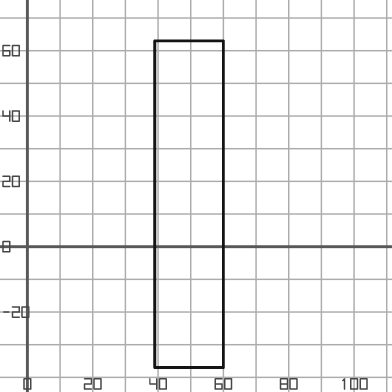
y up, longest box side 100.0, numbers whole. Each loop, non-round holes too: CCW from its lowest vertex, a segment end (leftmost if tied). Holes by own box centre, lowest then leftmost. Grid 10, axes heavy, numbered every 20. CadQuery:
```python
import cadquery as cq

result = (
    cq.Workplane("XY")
    .moveTo(39.0, -37.0)
    .lineTo(60.0, -37.0)
    .lineTo(60.0, 63.0)
    .lineTo(39.0, 63.0)
    .close()
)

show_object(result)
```